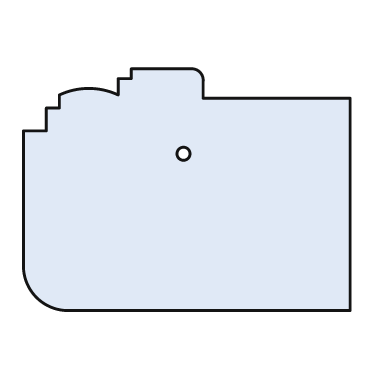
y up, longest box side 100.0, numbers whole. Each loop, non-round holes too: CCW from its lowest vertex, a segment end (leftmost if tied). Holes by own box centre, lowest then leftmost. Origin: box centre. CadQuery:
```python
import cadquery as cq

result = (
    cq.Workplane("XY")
    .moveTo(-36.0, -37.0)
    .lineTo(50.0, -37.0)
    .lineTo(50.0, 28.0)
    .lineTo(5.0, 28.0)
    .lineTo(5.0, 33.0)
    .threePointArc((4.0, 36.0), (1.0, 37.0))
    .lineTo(-17.0, 37.0)
    .lineTo(-17.0, 34.0)
    .lineTo(-21.0, 34.0)
    .lineTo(-21.0, 29.0)
    .threePointArc((-30.0, 31.0), (-39.0, 29.0))
    .lineTo(-39.0, 25.0)
    .lineTo(-43.0, 25.0)
    .lineTo(-43.0, 18.0)
    .lineTo(-50.0, 18.0)
    .lineTo(-50.0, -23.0)
    .threePointArc((-46.0, -33.0), (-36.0, -37.0))
    .close()
    .moveTo(-1.0, 11.0)
    .circle(2.0)
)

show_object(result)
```